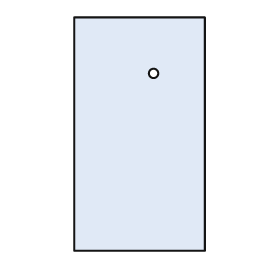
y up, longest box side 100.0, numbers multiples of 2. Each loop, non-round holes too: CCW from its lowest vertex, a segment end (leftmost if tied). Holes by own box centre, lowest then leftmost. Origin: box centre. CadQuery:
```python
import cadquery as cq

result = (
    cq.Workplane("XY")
    .moveTo(-28.0, -50.0)
    .lineTo(28.0, -50.0)
    .lineTo(28.0, 50.0)
    .lineTo(-28.0, 50.0)
    .close()
    .moveTo(6.0, 26.0)
    .circle(2.0)
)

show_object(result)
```